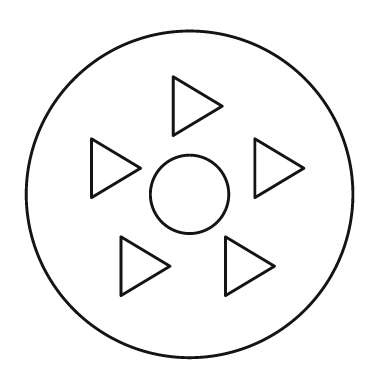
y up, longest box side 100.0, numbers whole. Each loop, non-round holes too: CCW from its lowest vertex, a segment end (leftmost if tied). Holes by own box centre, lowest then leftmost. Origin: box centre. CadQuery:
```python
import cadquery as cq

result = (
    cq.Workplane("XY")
    .moveTo(0.0, 0.0)
    .circle(50.0)
    .moveTo(-21.0, -31.0)
    .lineTo(-6.0, -22.0)
    .lineTo(-21.0, -13.0)
    .close()
    .moveTo(11.0, -31.0)
    .lineTo(26.0, -22.0)
    .lineTo(11.0, -13.0)
    .close()
    .moveTo(0.0, 0.0)
    .circle(12.0)
    .moveTo(-30.0, -1.0)
    .lineTo(-15.0, 8.0)
    .lineTo(-30.0, 17.0)
    .close()
    .moveTo(20.0, -1.0)
    .lineTo(35.0, 8.0)
    .lineTo(20.0, 17.0)
    .close()
    .moveTo(-5.0, 18.0)
    .lineTo(10.0, 27.0)
    .lineTo(-5.0, 36.0)
    .close()
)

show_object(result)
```